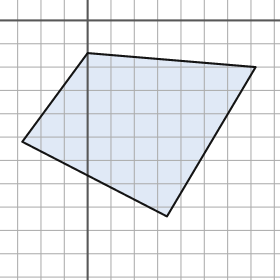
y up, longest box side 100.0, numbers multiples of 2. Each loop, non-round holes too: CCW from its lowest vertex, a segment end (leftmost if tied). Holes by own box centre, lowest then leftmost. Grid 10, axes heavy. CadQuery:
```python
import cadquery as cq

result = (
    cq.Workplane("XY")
    .moveTo(34.0, -84.0)
    .lineTo(72.0, -20.0)
    .lineTo(0.0, -14.0)
    .lineTo(-28.0, -52.0)
    .close()
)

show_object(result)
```